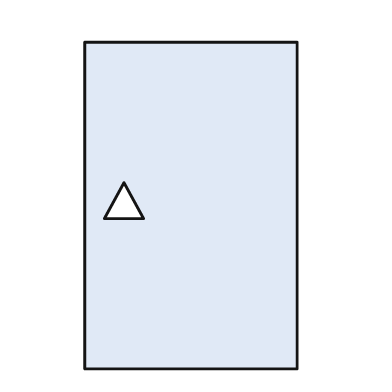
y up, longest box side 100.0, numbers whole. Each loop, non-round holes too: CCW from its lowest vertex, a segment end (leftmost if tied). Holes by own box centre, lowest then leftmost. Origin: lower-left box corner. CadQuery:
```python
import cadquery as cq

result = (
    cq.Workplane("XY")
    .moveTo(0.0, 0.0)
    .lineTo(65.0, 0.0)
    .lineTo(65.0, 100.0)
    .lineTo(0.0, 100.0)
    .close()
    .moveTo(6.0, 46.0)
    .lineTo(18.0, 46.0)
    .lineTo(12.0, 57.0)
    .close()
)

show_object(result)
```